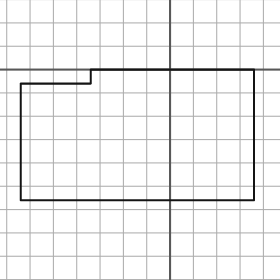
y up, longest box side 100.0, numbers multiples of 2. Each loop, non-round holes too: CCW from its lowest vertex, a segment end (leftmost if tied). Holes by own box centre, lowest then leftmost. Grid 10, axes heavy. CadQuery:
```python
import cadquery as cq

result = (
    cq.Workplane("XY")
    .moveTo(-64.0, -56.0)
    .lineTo(36.0, -56.0)
    .lineTo(36.0, 0.0)
    .lineTo(-34.0, 0.0)
    .lineTo(-34.0, -6.0)
    .lineTo(-64.0, -6.0)
    .close()
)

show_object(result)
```